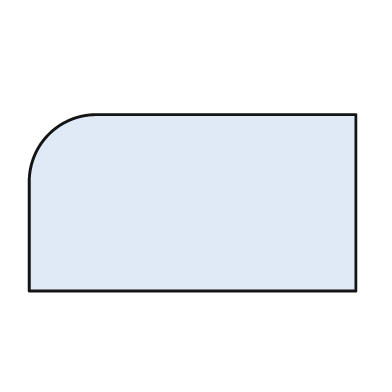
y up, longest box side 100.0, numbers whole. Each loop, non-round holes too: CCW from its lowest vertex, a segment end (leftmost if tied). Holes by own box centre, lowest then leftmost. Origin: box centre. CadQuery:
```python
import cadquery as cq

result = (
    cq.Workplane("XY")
    .moveTo(-50.0, -27.0)
    .lineTo(50.0, -27.0)
    .lineTo(50.0, 27.0)
    .lineTo(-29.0, 27.0)
    .threePointArc((-44.0, 21.0), (-50.0, 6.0))
    .close()
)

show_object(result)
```